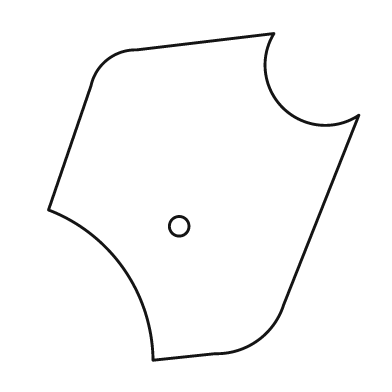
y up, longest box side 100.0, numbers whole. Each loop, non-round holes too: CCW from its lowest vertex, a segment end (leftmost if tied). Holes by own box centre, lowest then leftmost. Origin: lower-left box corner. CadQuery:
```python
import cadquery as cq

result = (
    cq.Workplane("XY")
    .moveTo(32.0, 0.0)
    .lineTo(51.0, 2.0)
    .threePointArc((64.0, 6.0), (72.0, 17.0))
    .lineTo(95.0, 75.0)
    .threePointArc((72.0, 77.0), (69.0, 100.0))
    .lineTo(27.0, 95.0)
    .threePointArc((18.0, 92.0), (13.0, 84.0))
    .lineTo(0.0, 46.0)
    .threePointArc((23.0, 28.0), (32.0, 0.0))
    .close()
    .moveTo(40.0, 41.0)
    .circle(3.0)
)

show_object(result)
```